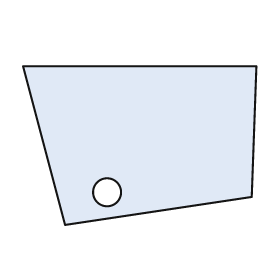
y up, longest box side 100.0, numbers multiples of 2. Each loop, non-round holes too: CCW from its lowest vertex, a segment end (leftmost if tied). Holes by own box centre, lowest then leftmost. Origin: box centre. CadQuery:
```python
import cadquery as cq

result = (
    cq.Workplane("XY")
    .moveTo(-32.0, -34.0)
    .lineTo(48.0, -22.0)
    .lineTo(50.0, 34.0)
    .lineTo(-50.0, 34.0)
    .close()
    .moveTo(-14.0, -20.0)
    .circle(6.0)
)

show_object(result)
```